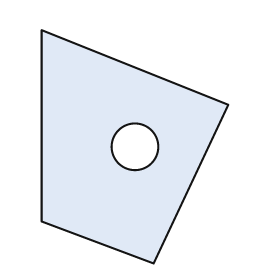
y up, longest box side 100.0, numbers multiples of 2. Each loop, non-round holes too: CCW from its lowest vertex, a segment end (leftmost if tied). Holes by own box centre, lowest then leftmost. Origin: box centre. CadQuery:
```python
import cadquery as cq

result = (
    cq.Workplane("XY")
    .moveTo(8.0, -50.0)
    .lineTo(40.0, 18.0)
    .lineTo(-40.0, 50.0)
    .lineTo(-40.0, -32.0)
    .close()
    .moveTo(0.0, 0.0)
    .circle(10.0)
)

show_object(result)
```